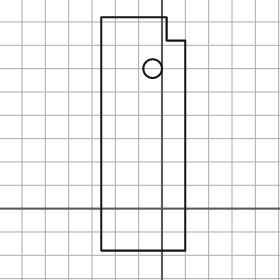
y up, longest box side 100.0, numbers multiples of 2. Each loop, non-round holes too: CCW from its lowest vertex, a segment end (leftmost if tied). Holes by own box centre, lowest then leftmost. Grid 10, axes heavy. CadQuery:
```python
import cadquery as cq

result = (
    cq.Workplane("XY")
    .moveTo(-26.0, -18.0)
    .lineTo(10.0, -18.0)
    .lineTo(10.0, 72.0)
    .lineTo(2.0, 72.0)
    .lineTo(2.0, 82.0)
    .lineTo(-26.0, 82.0)
    .close()
    .moveTo(-4.0, 60.0)
    .circle(4.0)
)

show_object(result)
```